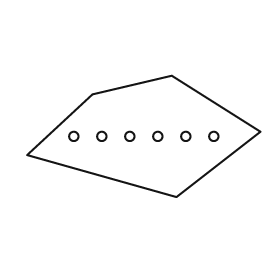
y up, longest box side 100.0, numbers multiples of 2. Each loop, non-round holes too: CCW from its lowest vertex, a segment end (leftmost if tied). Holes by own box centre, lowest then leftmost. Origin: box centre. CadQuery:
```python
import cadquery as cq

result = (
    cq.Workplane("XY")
    .moveTo(14.0, -26.0)
    .lineTo(50.0, 2.0)
    .lineTo(12.0, 26.0)
    .lineTo(-22.0, 18.0)
    .lineTo(-50.0, -8.0)
    .close()
    .moveTo(-30.0, 0.0)
    .circle(2.0)
    .moveTo(-18.0, 0.0)
    .circle(2.0)
    .moveTo(-6.0, 0.0)
    .circle(2.0)
    .moveTo(6.0, 0.0)
    .circle(2.0)
    .moveTo(18.0, 0.0)
    .circle(2.0)
    .moveTo(30.0, 0.0)
    .circle(2.0)
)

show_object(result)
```